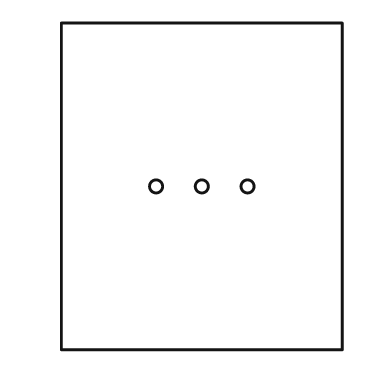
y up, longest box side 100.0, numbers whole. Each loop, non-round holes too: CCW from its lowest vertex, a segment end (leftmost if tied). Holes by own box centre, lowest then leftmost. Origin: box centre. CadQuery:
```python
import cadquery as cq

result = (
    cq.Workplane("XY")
    .moveTo(-43.0, -50.0)
    .lineTo(43.0, -50.0)
    .lineTo(43.0, 50.0)
    .lineTo(-43.0, 50.0)
    .close()
    .moveTo(-14.0, 0.0)
    .circle(2.0)
    .moveTo(0.0, 0.0)
    .circle(2.0)
    .moveTo(14.0, 0.0)
    .circle(2.0)
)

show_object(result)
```